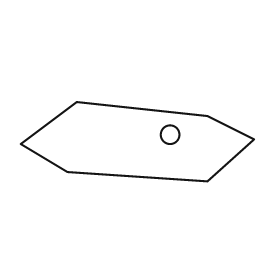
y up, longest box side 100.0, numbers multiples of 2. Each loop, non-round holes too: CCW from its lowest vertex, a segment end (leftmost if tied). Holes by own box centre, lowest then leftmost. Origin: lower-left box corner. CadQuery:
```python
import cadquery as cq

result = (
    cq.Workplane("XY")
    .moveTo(80.0, 0.0)
    .lineTo(100.0, 18.0)
    .lineTo(80.0, 28.0)
    .lineTo(24.0, 34.0)
    .lineTo(0.0, 16.0)
    .lineTo(20.0, 4.0)
    .close()
    .moveTo(64.0, 20.0)
    .circle(4.0)
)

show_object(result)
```